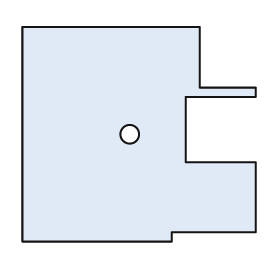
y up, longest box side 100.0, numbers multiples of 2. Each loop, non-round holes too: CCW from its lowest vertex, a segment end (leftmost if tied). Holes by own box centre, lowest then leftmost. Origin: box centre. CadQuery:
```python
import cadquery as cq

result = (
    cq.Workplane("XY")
    .moveTo(-50.0, -46.0)
    .lineTo(14.0, -46.0)
    .lineTo(14.0, -42.0)
    .lineTo(50.0, -42.0)
    .lineTo(50.0, -12.0)
    .lineTo(20.0, -12.0)
    .lineTo(20.0, 16.0)
    .lineTo(50.0, 16.0)
    .lineTo(50.0, 20.0)
    .lineTo(26.0, 20.0)
    .lineTo(26.0, 46.0)
    .lineTo(-50.0, 46.0)
    .close()
    .moveTo(-4.0, 0.0)
    .circle(4.0)
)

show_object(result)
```